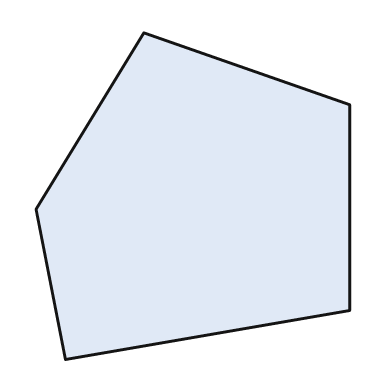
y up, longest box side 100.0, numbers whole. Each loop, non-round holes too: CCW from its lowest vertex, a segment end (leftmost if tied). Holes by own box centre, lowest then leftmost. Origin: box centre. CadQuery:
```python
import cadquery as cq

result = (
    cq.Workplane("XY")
    .moveTo(-39.0, -50.0)
    .lineTo(48.0, -35.0)
    .lineTo(48.0, 28.0)
    .lineTo(-15.0, 50.0)
    .lineTo(-48.0, -4.0)
    .close()
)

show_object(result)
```